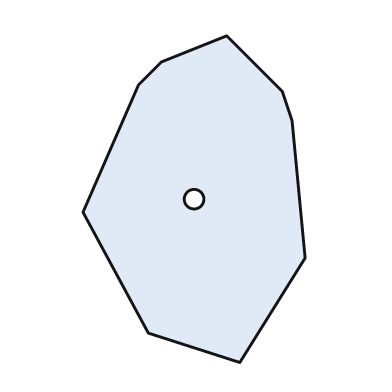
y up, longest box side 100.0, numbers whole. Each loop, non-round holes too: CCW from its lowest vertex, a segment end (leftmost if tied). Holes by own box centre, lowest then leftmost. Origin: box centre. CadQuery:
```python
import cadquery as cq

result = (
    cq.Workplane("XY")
    .moveTo(14.0, -50.0)
    .lineTo(34.0, -18.0)
    .lineTo(30.0, 24.0)
    .lineTo(27.0, 33.0)
    .lineTo(10.0, 50.0)
    .lineTo(-10.0, 42.0)
    .lineTo(-17.0, 35.0)
    .lineTo(-34.0, -4.0)
    .lineTo(-14.0, -41.0)
    .close()
    .moveTo(0.0, 0.0)
    .circle(3.0)
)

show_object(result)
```